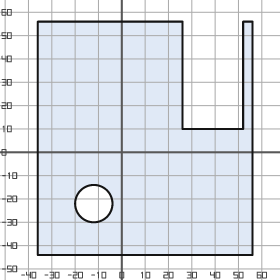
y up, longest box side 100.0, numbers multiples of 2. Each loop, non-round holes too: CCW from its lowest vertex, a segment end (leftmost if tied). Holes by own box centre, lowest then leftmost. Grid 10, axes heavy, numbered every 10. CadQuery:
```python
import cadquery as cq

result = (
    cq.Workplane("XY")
    .moveTo(-36.0, -44.0)
    .lineTo(56.0, -44.0)
    .lineTo(56.0, 56.0)
    .lineTo(52.0, 56.0)
    .lineTo(52.0, 10.0)
    .lineTo(26.0, 10.0)
    .lineTo(26.0, 56.0)
    .lineTo(-36.0, 56.0)
    .close()
    .moveTo(-12.0, -22.0)
    .circle(8.0)
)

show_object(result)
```